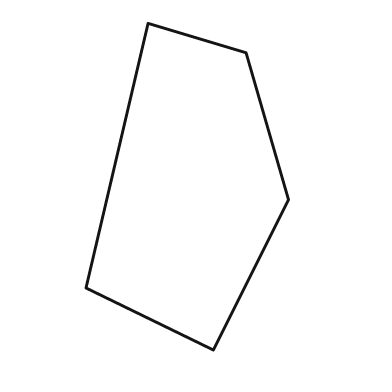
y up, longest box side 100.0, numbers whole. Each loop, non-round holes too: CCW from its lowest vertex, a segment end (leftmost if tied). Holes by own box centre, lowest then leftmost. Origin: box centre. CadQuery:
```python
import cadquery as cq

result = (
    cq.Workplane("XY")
    .moveTo(8.0, -50.0)
    .lineTo(31.0, -4.0)
    .lineTo(18.0, 41.0)
    .lineTo(-12.0, 50.0)
    .lineTo(-31.0, -31.0)
    .close()
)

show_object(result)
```